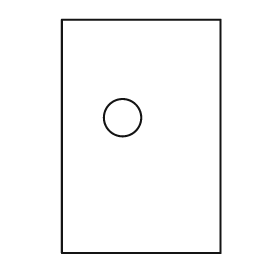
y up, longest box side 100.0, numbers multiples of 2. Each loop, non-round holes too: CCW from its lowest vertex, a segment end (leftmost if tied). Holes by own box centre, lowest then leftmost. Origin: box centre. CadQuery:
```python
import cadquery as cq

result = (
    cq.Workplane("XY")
    .moveTo(-34.0, -50.0)
    .lineTo(34.0, -50.0)
    .lineTo(34.0, 50.0)
    .lineTo(-34.0, 50.0)
    .close()
    .moveTo(-8.0, 8.0)
    .circle(8.0)
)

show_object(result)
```